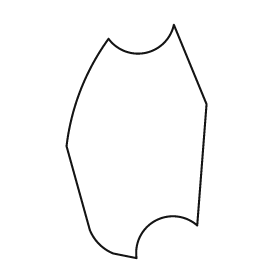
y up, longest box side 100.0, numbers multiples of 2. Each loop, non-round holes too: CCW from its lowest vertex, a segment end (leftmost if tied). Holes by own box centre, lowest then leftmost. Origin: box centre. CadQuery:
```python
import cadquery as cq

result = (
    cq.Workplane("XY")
    .moveTo(0.0, -50.0)
    .threePointArc((8.0, -34.0), (26.0, -36.0))
    .lineTo(30.0, 16.0)
    .lineTo(16.0, 50.0)
    .threePointArc((4.0, 38.0), (-12.0, 44.0))
    .threePointArc((-24.0, 22.0), (-30.0, -2.0))
    .lineTo(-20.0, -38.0)
    .threePointArc((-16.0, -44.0), (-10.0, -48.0))
    .close()
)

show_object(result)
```